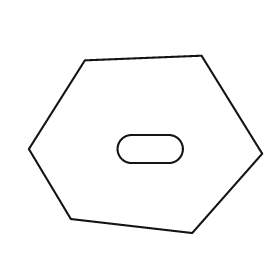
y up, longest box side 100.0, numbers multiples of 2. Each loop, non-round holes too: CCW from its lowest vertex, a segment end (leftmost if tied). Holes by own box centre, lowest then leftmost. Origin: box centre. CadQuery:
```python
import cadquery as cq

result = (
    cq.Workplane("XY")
    .moveTo(20.0, -38.0)
    .lineTo(50.0, -4.0)
    .lineTo(24.0, 38.0)
    .lineTo(-26.0, 36.0)
    .lineTo(-50.0, -2.0)
    .lineTo(-32.0, -32.0)
    .close()
    .moveTo(-6.0, -8.0)
    .lineTo(10.0, -8.0)
    .threePointArc((16.0, -2.0), (10.0, 4.0))
    .lineTo(-6.0, 4.0)
    .threePointArc((-12.0, -2.0), (-6.0, -8.0))
    .close()
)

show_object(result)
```